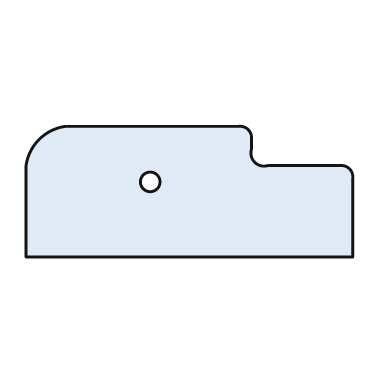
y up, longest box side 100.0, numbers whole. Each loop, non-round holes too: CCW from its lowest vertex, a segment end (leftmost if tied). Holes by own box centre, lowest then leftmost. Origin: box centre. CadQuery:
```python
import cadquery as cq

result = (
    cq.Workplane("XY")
    .moveTo(-50.0, -20.0)
    .lineTo(50.0, -20.0)
    .lineTo(50.0, 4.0)
    .threePointArc((49.0, 7.0), (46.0, 8.0))
    .lineTo(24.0, 8.0)
    .threePointArc((20.0, 9.0), (19.0, 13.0))
    .lineTo(19.0, 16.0)
    .threePointArc((18.0, 19.0), (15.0, 20.0))
    .lineTo(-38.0, 20.0)
    .threePointArc((-46.0, 16.0), (-50.0, 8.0))
    .close()
    .moveTo(-12.0, 3.0)
    .circle(3.0)
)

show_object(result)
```